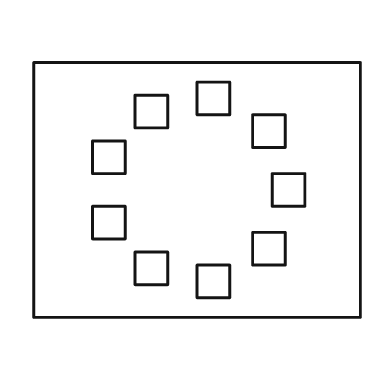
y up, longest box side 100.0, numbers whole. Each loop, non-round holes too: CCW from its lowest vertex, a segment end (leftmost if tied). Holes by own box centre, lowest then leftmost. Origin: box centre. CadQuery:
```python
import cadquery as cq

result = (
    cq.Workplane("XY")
    .moveTo(-50.0, -39.0)
    .lineTo(50.0, -39.0)
    .lineTo(50.0, 39.0)
    .lineTo(-50.0, 39.0)
    .close()
    .moveTo(0.0, -33.0)
    .lineTo(10.0, -33.0)
    .lineTo(10.0, -23.0)
    .lineTo(0.0, -23.0)
    .close()
    .moveTo(-19.0, -29.0)
    .lineTo(-9.0, -29.0)
    .lineTo(-9.0, -19.0)
    .lineTo(-19.0, -19.0)
    .close()
    .moveTo(17.0, -23.0)
    .lineTo(27.0, -23.0)
    .lineTo(27.0, -13.0)
    .lineTo(17.0, -13.0)
    .close()
    .moveTo(-32.0, -15.0)
    .lineTo(-22.0, -15.0)
    .lineTo(-22.0, -5.0)
    .lineTo(-32.0, -5.0)
    .close()
    .moveTo(23.0, -5.0)
    .lineTo(33.0, -5.0)
    .lineTo(33.0, 5.0)
    .lineTo(23.0, 5.0)
    .close()
    .moveTo(-32.0, 5.0)
    .lineTo(-22.0, 5.0)
    .lineTo(-22.0, 15.0)
    .lineTo(-32.0, 15.0)
    .close()
    .moveTo(17.0, 13.0)
    .lineTo(27.0, 13.0)
    .lineTo(27.0, 23.0)
    .lineTo(17.0, 23.0)
    .close()
    .moveTo(-19.0, 19.0)
    .lineTo(-9.0, 19.0)
    .lineTo(-9.0, 29.0)
    .lineTo(-19.0, 29.0)
    .close()
    .moveTo(0.0, 23.0)
    .lineTo(10.0, 23.0)
    .lineTo(10.0, 33.0)
    .lineTo(0.0, 33.0)
    .close()
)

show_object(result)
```